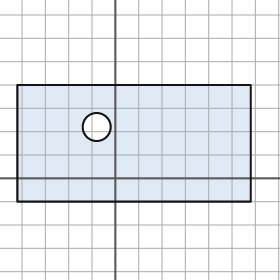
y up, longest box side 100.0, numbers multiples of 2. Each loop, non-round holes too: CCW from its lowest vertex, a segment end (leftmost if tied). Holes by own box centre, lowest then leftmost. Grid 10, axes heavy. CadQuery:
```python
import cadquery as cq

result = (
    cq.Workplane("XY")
    .moveTo(-42.0, -10.0)
    .lineTo(58.0, -10.0)
    .lineTo(58.0, 40.0)
    .lineTo(-42.0, 40.0)
    .close()
    .moveTo(-8.0, 22.0)
    .circle(6.0)
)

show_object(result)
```